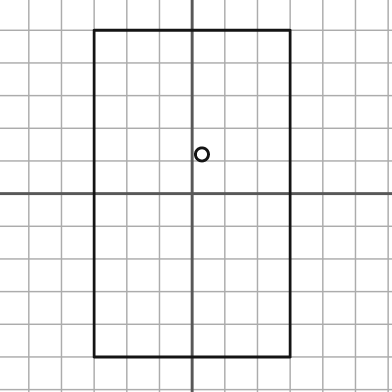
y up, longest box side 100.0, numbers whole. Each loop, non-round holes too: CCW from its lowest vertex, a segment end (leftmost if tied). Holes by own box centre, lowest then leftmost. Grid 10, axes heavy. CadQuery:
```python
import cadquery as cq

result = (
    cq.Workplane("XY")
    .moveTo(-30.0, -50.0)
    .lineTo(30.0, -50.0)
    .lineTo(30.0, 50.0)
    .lineTo(-30.0, 50.0)
    .close()
    .moveTo(3.0, 12.0)
    .circle(2.0)
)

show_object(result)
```